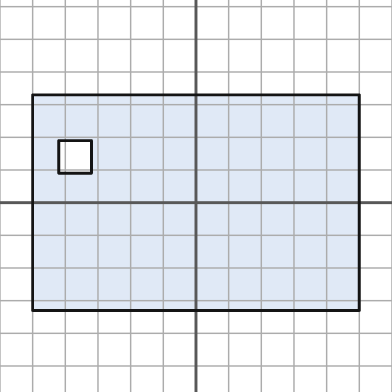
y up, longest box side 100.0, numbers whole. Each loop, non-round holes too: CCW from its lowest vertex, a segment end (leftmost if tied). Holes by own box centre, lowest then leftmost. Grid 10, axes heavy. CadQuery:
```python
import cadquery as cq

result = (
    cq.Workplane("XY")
    .moveTo(-50.0, -33.0)
    .lineTo(50.0, -33.0)
    .lineTo(50.0, 33.0)
    .lineTo(-50.0, 33.0)
    .close()
    .moveTo(-42.0, 9.0)
    .lineTo(-32.0, 9.0)
    .lineTo(-32.0, 19.0)
    .lineTo(-42.0, 19.0)
    .close()
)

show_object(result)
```